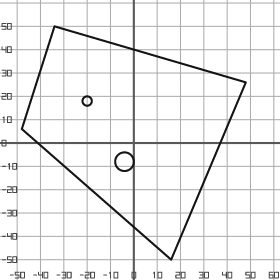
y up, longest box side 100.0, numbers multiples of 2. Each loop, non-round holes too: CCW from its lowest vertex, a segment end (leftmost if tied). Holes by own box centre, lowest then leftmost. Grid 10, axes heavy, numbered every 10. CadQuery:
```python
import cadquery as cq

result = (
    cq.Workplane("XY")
    .moveTo(16.0, -50.0)
    .lineTo(48.0, 26.0)
    .lineTo(-34.0, 50.0)
    .lineTo(-48.0, 6.0)
    .close()
    .moveTo(-4.0, -8.0)
    .circle(4.0)
    .moveTo(-20.0, 18.0)
    .circle(2.0)
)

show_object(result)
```